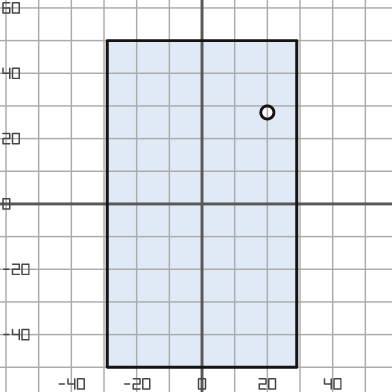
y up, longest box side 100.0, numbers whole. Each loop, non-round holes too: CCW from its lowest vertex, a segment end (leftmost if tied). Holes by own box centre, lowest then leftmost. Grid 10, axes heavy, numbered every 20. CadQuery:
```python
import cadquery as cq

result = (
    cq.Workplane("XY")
    .moveTo(-29.0, -50.0)
    .lineTo(29.0, -50.0)
    .lineTo(29.0, 50.0)
    .lineTo(-29.0, 50.0)
    .close()
    .moveTo(20.0, 28.0)
    .circle(2.0)
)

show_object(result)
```